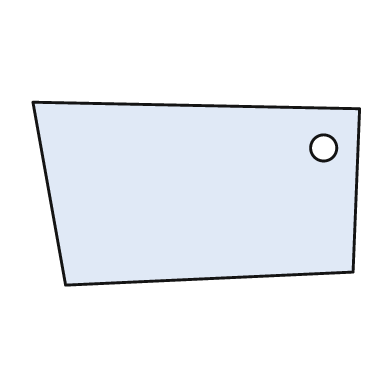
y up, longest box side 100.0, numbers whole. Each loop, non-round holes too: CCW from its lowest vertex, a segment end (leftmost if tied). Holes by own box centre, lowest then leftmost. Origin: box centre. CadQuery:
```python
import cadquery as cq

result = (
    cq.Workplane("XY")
    .moveTo(-40.0, -28.0)
    .lineTo(48.0, -24.0)
    .lineTo(50.0, 26.0)
    .lineTo(-50.0, 28.0)
    .close()
    .moveTo(39.0, 14.0)
    .circle(4.0)
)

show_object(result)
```